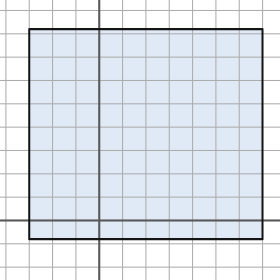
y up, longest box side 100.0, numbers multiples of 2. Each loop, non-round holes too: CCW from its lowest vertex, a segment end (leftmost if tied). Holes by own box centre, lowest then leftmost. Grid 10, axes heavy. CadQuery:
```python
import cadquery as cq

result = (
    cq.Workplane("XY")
    .moveTo(-30.0, -8.0)
    .lineTo(70.0, -8.0)
    .lineTo(70.0, 82.0)
    .lineTo(-30.0, 82.0)
    .close()
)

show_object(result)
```